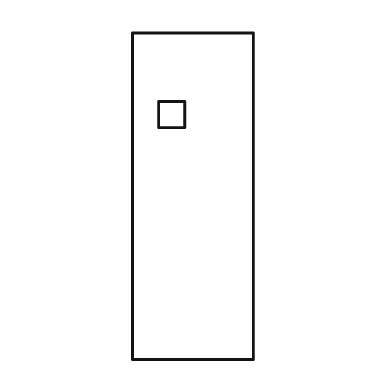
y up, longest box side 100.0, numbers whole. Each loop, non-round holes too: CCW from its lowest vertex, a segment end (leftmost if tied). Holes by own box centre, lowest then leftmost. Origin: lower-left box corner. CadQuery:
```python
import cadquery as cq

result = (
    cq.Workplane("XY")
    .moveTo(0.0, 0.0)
    .lineTo(37.0, 0.0)
    .lineTo(37.0, 100.0)
    .lineTo(0.0, 100.0)
    .close()
    .moveTo(8.0, 71.0)
    .lineTo(16.0, 71.0)
    .lineTo(16.0, 79.0)
    .lineTo(8.0, 79.0)
    .close()
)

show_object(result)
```